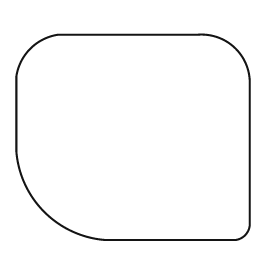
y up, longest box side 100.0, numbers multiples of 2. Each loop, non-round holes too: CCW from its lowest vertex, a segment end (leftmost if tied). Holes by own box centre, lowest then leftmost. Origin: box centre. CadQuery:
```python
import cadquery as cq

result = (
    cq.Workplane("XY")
    .moveTo(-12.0, -44.0)
    .lineTo(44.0, -44.0)
    .threePointArc((48.0, -42.0), (50.0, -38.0))
    .lineTo(50.0, 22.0)
    .threePointArc((44.0, 38.0), (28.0, 44.0))
    .lineTo(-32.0, 44.0)
    .threePointArc((-44.0, 38.0), (-50.0, 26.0))
    .lineTo(-50.0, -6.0)
    .threePointArc((-38.0, -32.0), (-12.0, -44.0))
    .close()
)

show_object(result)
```